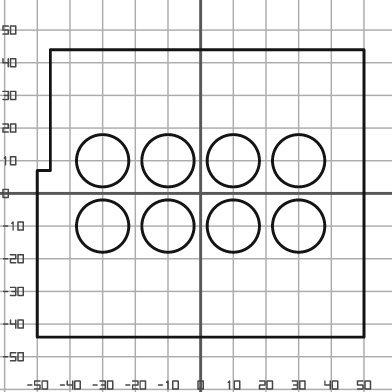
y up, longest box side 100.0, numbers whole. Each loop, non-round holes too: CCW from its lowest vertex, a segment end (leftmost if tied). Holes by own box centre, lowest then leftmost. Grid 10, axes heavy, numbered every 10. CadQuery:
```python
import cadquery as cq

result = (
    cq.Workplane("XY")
    .moveTo(-50.0, -44.0)
    .lineTo(50.0, -44.0)
    .lineTo(50.0, 44.0)
    .lineTo(-46.0, 44.0)
    .lineTo(-46.0, 7.0)
    .lineTo(-50.0, 7.0)
    .close()
    .moveTo(-30.0, -10.0)
    .circle(8.0)
    .moveTo(-10.0, -10.0)
    .circle(8.0)
    .moveTo(10.0, -10.0)
    .circle(8.0)
    .moveTo(30.0, -10.0)
    .circle(8.0)
    .moveTo(-30.0, 10.0)
    .circle(8.0)
    .moveTo(-10.0, 10.0)
    .circle(8.0)
    .moveTo(10.0, 10.0)
    .circle(8.0)
    .moveTo(30.0, 10.0)
    .circle(8.0)
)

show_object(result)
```